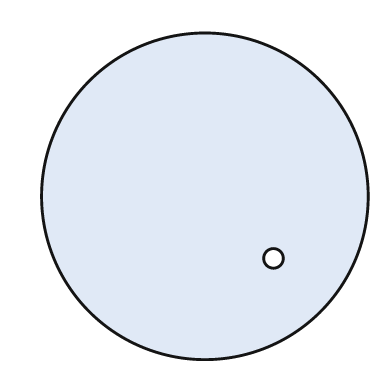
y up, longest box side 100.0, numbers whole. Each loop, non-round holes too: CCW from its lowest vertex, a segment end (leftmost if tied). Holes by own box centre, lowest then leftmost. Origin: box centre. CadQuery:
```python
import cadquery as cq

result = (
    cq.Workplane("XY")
    .moveTo(0.0, 0.0)
    .circle(50.0)
    .moveTo(21.0, -19.0)
    .circle(3.0)
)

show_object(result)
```